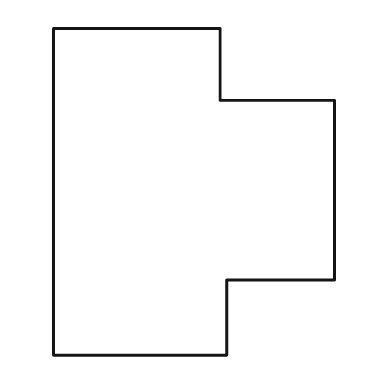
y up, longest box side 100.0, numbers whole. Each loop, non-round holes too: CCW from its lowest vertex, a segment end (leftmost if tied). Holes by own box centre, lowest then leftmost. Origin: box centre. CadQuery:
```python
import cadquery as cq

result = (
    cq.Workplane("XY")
    .moveTo(-43.0, -50.0)
    .lineTo(10.0, -50.0)
    .lineTo(10.0, -27.0)
    .lineTo(43.0, -27.0)
    .lineTo(43.0, 28.0)
    .lineTo(8.0, 28.0)
    .lineTo(8.0, 50.0)
    .lineTo(-43.0, 50.0)
    .close()
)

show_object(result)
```